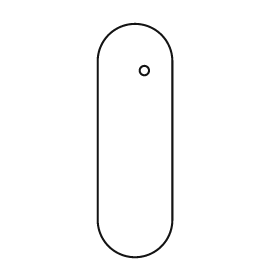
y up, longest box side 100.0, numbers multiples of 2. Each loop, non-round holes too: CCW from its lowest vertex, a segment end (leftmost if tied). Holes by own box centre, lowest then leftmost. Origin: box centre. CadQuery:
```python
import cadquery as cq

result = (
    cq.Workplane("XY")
    .moveTo(-16.0, -34.0)
    .threePointArc((0.0, -50.0), (16.0, -34.0))
    .lineTo(16.0, 34.0)
    .threePointArc((0.0, 50.0), (-16.0, 34.0))
    .close()
    .moveTo(4.0, 30.0)
    .circle(2.0)
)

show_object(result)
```